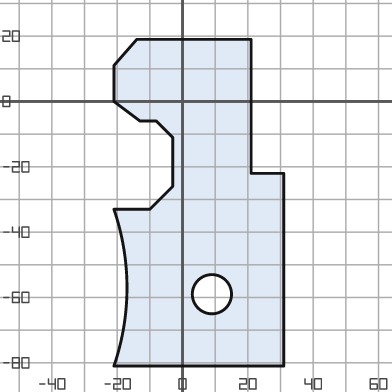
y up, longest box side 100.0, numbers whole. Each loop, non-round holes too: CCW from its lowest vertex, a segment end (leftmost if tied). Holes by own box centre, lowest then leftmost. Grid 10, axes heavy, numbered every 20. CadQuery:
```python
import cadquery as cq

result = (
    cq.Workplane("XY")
    .moveTo(-21.0, -81.0)
    .lineTo(31.0, -81.0)
    .lineTo(31.0, -22.0)
    .lineTo(21.0, -22.0)
    .lineTo(21.0, 19.0)
    .lineTo(-14.0, 19.0)
    .lineTo(-21.0, 11.0)
    .lineTo(-21.0, 0.0)
    .lineTo(-13.0, -6.0)
    .lineTo(-8.0, -6.0)
    .lineTo(-3.0, -11.0)
    .lineTo(-3.0, -26.0)
    .lineTo(-10.0, -33.0)
    .lineTo(-21.0, -33.0)
    .threePointArc((-17.0, -57.0), (-21.0, -81.0))
    .close()
    .moveTo(9.0, -59.0)
    .circle(6.0)
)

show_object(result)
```